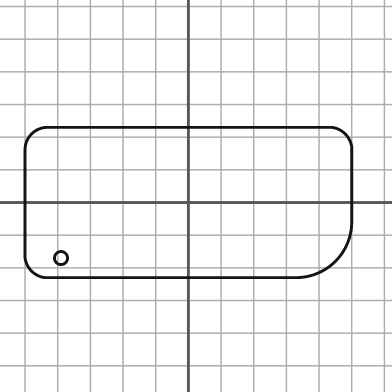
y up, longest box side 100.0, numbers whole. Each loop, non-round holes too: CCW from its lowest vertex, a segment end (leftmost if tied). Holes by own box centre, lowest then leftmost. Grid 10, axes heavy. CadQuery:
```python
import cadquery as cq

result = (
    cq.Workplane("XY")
    .moveTo(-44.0, -23.0)
    .lineTo(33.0, -23.0)
    .threePointArc((45.0, -18.0), (50.0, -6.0))
    .lineTo(50.0, 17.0)
    .threePointArc((48.0, 21.0), (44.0, 23.0))
    .lineTo(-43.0, 23.0)
    .threePointArc((-48.0, 21.0), (-50.0, 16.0))
    .lineTo(-50.0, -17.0)
    .threePointArc((-48.0, -21.0), (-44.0, -23.0))
    .close()
    .moveTo(-39.0, -17.0)
    .circle(2.0)
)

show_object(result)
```